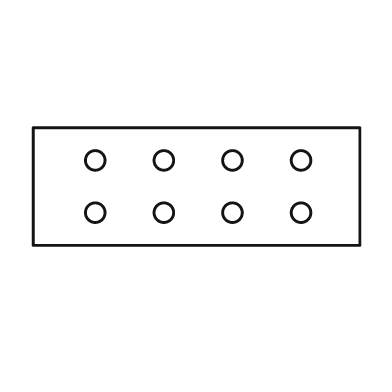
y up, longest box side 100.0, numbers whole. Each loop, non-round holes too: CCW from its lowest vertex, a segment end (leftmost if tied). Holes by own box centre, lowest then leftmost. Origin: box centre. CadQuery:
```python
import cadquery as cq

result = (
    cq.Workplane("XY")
    .moveTo(-50.0, -18.0)
    .lineTo(50.0, -18.0)
    .lineTo(50.0, 18.0)
    .lineTo(-50.0, 18.0)
    .close()
    .moveTo(-31.0, -8.0)
    .circle(3.0)
    .moveTo(-10.0, -8.0)
    .circle(3.0)
    .moveTo(11.0, -8.0)
    .circle(3.0)
    .moveTo(32.0, -8.0)
    .circle(3.0)
    .moveTo(-31.0, 8.0)
    .circle(3.0)
    .moveTo(-10.0, 8.0)
    .circle(3.0)
    .moveTo(11.0, 8.0)
    .circle(3.0)
    .moveTo(32.0, 8.0)
    .circle(3.0)
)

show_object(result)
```